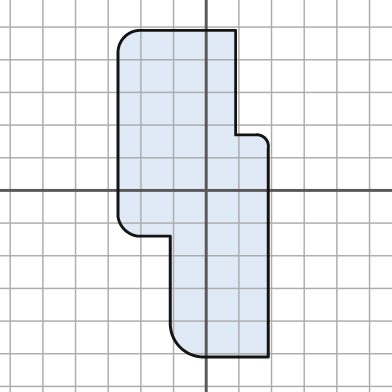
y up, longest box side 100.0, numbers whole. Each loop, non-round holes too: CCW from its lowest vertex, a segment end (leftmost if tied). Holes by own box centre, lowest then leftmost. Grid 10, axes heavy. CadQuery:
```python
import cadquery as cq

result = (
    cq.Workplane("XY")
    .moveTo(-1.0, -51.0)
    .lineTo(19.0, -51.0)
    .lineTo(19.0, 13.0)
    .threePointArc((18.0, 16.0), (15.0, 17.0))
    .lineTo(9.0, 17.0)
    .lineTo(9.0, 49.0)
    .lineTo(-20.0, 49.0)
    .threePointArc((-25.0, 47.0), (-27.0, 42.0))
    .lineTo(-27.0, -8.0)
    .threePointArc((-25.0, -12.0), (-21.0, -14.0))
    .lineTo(-11.0, -14.0)
    .lineTo(-11.0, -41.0)
    .threePointArc((-8.0, -48.0), (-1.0, -51.0))
    .close()
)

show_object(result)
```